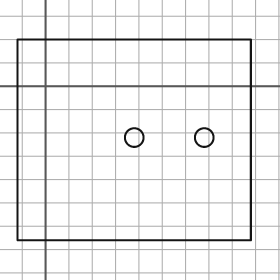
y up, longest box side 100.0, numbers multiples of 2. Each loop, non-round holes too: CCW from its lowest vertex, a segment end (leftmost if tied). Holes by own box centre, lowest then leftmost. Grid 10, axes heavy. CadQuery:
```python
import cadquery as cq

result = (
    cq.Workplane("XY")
    .moveTo(-12.0, -66.0)
    .lineTo(88.0, -66.0)
    .lineTo(88.0, 20.0)
    .lineTo(-12.0, 20.0)
    .close()
    .moveTo(38.0, -22.0)
    .circle(4.0)
    .moveTo(68.0, -22.0)
    .circle(4.0)
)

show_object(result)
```